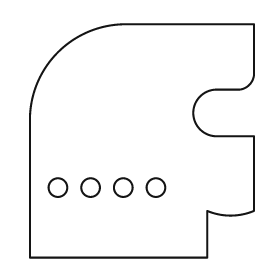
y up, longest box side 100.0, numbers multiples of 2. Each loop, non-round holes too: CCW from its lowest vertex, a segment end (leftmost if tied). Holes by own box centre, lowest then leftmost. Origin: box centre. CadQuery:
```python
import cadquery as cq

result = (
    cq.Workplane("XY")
    .moveTo(-48.0, -50.0)
    .lineTo(28.0, -50.0)
    .lineTo(28.0, -30.0)
    .threePointArc((38.0, -32.0), (48.0, -30.0))
    .lineTo(48.0, 2.0)
    .lineTo(32.0, 2.0)
    .threePointArc((22.0, 12.0), (32.0, 22.0))
    .lineTo(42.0, 22.0)
    .threePointArc((46.0, 24.0), (48.0, 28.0))
    .lineTo(48.0, 50.0)
    .lineTo(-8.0, 50.0)
    .threePointArc((-36.0, 38.0), (-48.0, 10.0))
    .close()
    .moveTo(-36.0, -20.0)
    .circle(4.0)
    .moveTo(-22.0, -20.0)
    .circle(4.0)
    .moveTo(-8.0, -20.0)
    .circle(4.0)
    .moveTo(6.0, -20.0)
    .circle(4.0)
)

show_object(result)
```